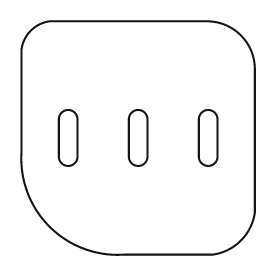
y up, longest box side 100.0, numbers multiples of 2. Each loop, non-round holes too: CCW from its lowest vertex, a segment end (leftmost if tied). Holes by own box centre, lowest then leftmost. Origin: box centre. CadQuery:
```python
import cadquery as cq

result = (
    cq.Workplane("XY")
    .moveTo(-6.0, -50.0)
    .lineTo(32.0, -50.0)
    .threePointArc((44.0, -44.0), (50.0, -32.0))
    .lineTo(50.0, 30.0)
    .threePointArc((44.0, 44.0), (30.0, 50.0))
    .lineTo(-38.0, 50.0)
    .threePointArc((-46.0, 46.0), (-50.0, 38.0))
    .lineTo(-50.0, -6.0)
    .threePointArc((-38.0, -38.0), (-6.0, -50.0))
    .close()
    .moveTo(-34.0, -8.0)
    .threePointArc((-30.0, -12.0), (-26.0, -8.0))
    .lineTo(-26.0, 8.0)
    .threePointArc((-30.0, 12.0), (-34.0, 8.0))
    .close()
    .moveTo(-4.0, -8.0)
    .threePointArc((0.0, -12.0), (4.0, -8.0))
    .lineTo(4.0, 8.0)
    .threePointArc((0.0, 12.0), (-4.0, 8.0))
    .close()
    .moveTo(26.0, -8.0)
    .threePointArc((30.0, -12.0), (34.0, -8.0))
    .lineTo(34.0, 8.0)
    .threePointArc((30.0, 12.0), (26.0, 8.0))
    .close()
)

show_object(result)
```